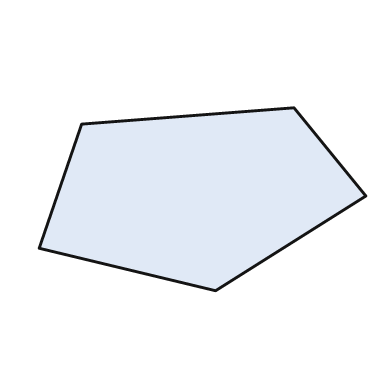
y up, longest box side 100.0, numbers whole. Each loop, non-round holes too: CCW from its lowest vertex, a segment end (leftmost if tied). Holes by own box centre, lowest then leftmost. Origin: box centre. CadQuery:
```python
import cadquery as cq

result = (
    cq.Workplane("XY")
    .moveTo(4.0, -28.0)
    .lineTo(50.0, 1.0)
    .lineTo(28.0, 28.0)
    .lineTo(-37.0, 23.0)
    .lineTo(-50.0, -15.0)
    .close()
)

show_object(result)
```